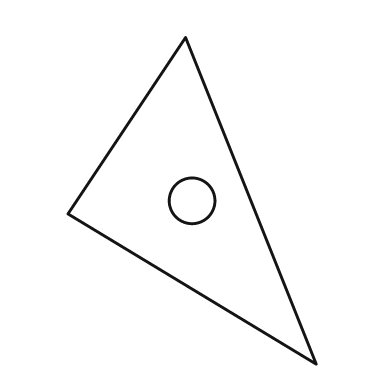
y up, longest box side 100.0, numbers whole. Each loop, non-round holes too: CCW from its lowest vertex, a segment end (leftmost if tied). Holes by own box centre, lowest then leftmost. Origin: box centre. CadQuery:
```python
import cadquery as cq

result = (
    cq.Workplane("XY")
    .moveTo(38.0, -50.0)
    .lineTo(-2.0, 50.0)
    .lineTo(-38.0, -4.0)
    .close()
    .moveTo(0.0, 0.0)
    .circle(7.0)
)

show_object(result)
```